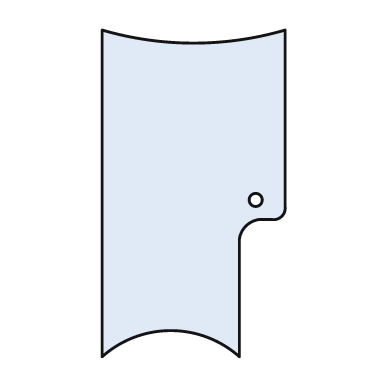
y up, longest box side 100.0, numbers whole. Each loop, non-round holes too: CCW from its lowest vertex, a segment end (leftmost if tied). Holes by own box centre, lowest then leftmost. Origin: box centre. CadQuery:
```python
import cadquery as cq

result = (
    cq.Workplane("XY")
    .moveTo(-28.0, -50.0)
    .threePointArc((-7.0, -42.0), (14.0, -50.0))
    .lineTo(14.0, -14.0)
    .threePointArc((16.0, -10.0), (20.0, -8.0))
    .lineTo(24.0, -8.0)
    .threePointArc((27.0, -7.0), (28.0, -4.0))
    .lineTo(28.0, 50.0)
    .threePointArc((0.0, 46.0), (-28.0, 50.0))
    .close()
    .moveTo(19.0, -2.0)
    .circle(2.0)
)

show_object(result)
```